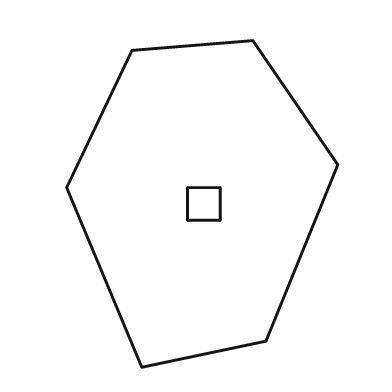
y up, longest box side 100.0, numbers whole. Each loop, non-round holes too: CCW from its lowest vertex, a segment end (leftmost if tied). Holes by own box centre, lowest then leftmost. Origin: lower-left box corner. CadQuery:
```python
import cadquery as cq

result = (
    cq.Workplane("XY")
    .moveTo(23.0, 0.0)
    .lineTo(61.0, 8.0)
    .lineTo(83.0, 62.0)
    .lineTo(57.0, 100.0)
    .lineTo(20.0, 97.0)
    .lineTo(0.0, 55.0)
    .close()
    .moveTo(37.0, 45.0)
    .lineTo(47.0, 45.0)
    .lineTo(47.0, 55.0)
    .lineTo(37.0, 55.0)
    .close()
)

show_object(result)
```